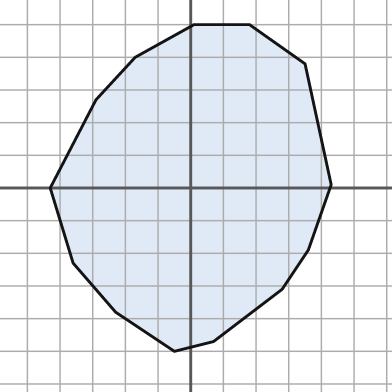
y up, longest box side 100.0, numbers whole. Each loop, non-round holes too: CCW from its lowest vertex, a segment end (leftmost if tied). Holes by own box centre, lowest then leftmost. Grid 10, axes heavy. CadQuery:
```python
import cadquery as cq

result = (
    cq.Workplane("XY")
    .moveTo(-5.0, -50.0)
    .lineTo(7.0, -47.0)
    .lineTo(28.0, -31.0)
    .lineTo(36.0, -19.0)
    .lineTo(43.0, 1.0)
    .lineTo(35.0, 38.0)
    .lineTo(18.0, 50.0)
    .lineTo(1.0, 50.0)
    .lineTo(-17.0, 40.0)
    .lineTo(-29.0, 27.0)
    .lineTo(-43.0, 0.0)
    .lineTo(-36.0, -23.0)
    .lineTo(-23.0, -38.0)
    .close()
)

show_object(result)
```